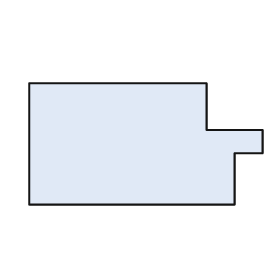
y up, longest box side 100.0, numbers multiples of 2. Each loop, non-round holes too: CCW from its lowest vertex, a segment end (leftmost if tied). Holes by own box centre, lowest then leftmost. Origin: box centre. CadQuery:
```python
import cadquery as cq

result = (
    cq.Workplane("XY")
    .moveTo(-50.0, -26.0)
    .lineTo(38.0, -26.0)
    .lineTo(38.0, -4.0)
    .lineTo(50.0, -4.0)
    .lineTo(50.0, 6.0)
    .lineTo(26.0, 6.0)
    .lineTo(26.0, 26.0)
    .lineTo(-50.0, 26.0)
    .close()
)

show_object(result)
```